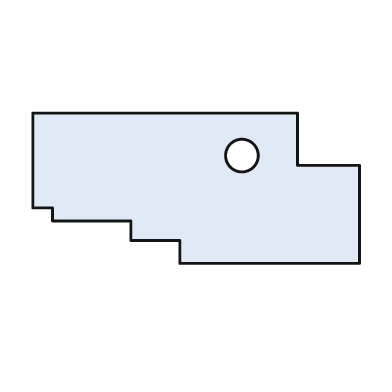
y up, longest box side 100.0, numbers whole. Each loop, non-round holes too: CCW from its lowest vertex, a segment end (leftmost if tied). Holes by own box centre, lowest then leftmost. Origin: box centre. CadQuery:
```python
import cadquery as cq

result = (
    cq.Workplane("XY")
    .moveTo(-5.0, -23.0)
    .lineTo(50.0, -23.0)
    .lineTo(50.0, 7.0)
    .lineTo(31.0, 7.0)
    .lineTo(31.0, 23.0)
    .lineTo(-50.0, 23.0)
    .lineTo(-50.0, -6.0)
    .lineTo(-44.0, -6.0)
    .lineTo(-44.0, -10.0)
    .lineTo(-20.0, -10.0)
    .lineTo(-20.0, -16.0)
    .lineTo(-5.0, -16.0)
    .close()
    .moveTo(14.0, 10.0)
    .circle(5.0)
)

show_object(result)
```